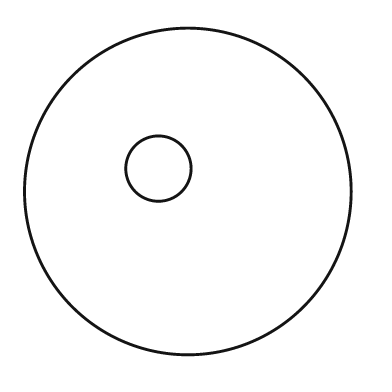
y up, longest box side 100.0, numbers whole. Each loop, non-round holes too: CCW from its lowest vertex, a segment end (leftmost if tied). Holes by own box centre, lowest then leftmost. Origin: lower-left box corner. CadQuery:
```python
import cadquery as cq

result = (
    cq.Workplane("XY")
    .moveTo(50.0, 50.0)
    .circle(50.0)
    .moveTo(41.0, 57.0)
    .circle(10.0)
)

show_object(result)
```